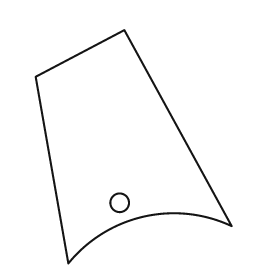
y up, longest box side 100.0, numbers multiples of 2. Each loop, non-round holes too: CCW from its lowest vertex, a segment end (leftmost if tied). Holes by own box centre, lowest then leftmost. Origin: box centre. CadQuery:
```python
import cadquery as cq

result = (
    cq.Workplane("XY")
    .moveTo(-28.0, -50.0)
    .threePointArc((4.0, -30.0), (42.0, -34.0))
    .lineTo(-4.0, 50.0)
    .lineTo(-42.0, 30.0)
    .close()
    .moveTo(-6.0, -24.0)
    .circle(4.0)
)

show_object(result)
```